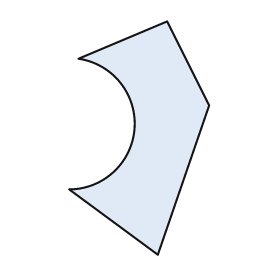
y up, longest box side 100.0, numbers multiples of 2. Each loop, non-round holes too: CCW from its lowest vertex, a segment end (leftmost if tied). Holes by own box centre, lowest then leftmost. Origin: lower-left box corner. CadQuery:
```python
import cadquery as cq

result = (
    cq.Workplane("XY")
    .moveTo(38.0, 0.0)
    .lineTo(60.0, 64.0)
    .lineTo(42.0, 100.0)
    .lineTo(4.0, 84.0)
    .threePointArc((28.0, 54.0), (0.0, 28.0))
    .close()
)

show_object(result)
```